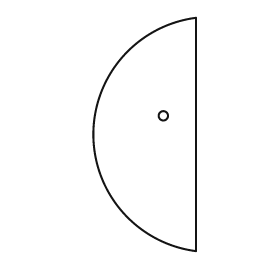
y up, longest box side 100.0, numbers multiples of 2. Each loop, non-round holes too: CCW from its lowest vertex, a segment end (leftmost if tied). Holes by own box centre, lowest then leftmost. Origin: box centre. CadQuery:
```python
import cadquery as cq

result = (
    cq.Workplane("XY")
    .moveTo(22.0, -50.0)
    .lineTo(22.0, 50.0)
    .threePointArc((-22.0, 0.0), (22.0, -50.0))
    .close()
    .moveTo(8.0, 8.0)
    .circle(2.0)
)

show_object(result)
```